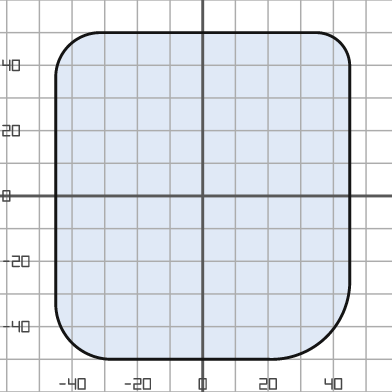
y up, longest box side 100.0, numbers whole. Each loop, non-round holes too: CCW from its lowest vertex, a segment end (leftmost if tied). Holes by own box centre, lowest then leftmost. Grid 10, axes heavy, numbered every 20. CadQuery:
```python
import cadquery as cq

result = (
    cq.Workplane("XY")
    .moveTo(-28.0, -50.0)
    .lineTo(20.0, -50.0)
    .threePointArc((38.0, -43.0), (45.0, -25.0))
    .lineTo(45.0, 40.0)
    .threePointArc((42.0, 47.0), (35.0, 50.0))
    .lineTo(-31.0, 50.0)
    .threePointArc((-41.0, 46.0), (-45.0, 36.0))
    .lineTo(-45.0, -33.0)
    .threePointArc((-40.0, -45.0), (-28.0, -50.0))
    .close()
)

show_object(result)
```